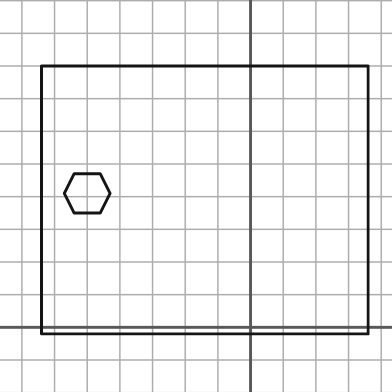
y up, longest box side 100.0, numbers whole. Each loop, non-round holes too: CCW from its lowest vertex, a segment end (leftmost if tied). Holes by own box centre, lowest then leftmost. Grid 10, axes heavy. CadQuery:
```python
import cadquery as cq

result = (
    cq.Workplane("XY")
    .moveTo(-64.0, -2.0)
    .lineTo(36.0, -2.0)
    .lineTo(36.0, 80.0)
    .lineTo(-64.0, 80.0)
    .close()
    .moveTo(-54.0, 35.0)
    .lineTo(-46.0, 35.0)
    .lineTo(-43.0, 41.0)
    .lineTo(-46.0, 47.0)
    .lineTo(-54.0, 47.0)
    .lineTo(-57.0, 41.0)
    .close()
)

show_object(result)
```